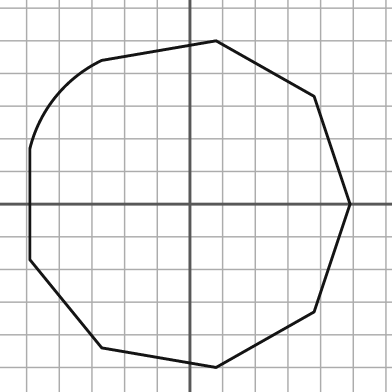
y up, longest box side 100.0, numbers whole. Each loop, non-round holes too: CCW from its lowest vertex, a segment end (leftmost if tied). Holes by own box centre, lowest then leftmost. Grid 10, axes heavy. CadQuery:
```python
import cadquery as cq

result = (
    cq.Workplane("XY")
    .moveTo(8.0, -50.0)
    .lineTo(38.0, -33.0)
    .lineTo(49.0, 0.0)
    .lineTo(38.0, 33.0)
    .lineTo(8.0, 50.0)
    .lineTo(-27.0, 44.0)
    .threePointArc((-41.0, 33.0), (-49.0, 17.0))
    .lineTo(-49.0, -17.0)
    .lineTo(-27.0, -44.0)
    .close()
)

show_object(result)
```